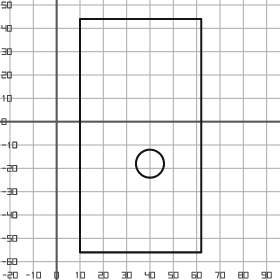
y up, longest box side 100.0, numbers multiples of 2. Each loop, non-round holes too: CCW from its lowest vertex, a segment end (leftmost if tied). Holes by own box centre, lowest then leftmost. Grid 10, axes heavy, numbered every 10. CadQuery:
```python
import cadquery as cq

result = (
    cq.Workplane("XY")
    .moveTo(10.0, -56.0)
    .lineTo(62.0, -56.0)
    .lineTo(62.0, 44.0)
    .lineTo(10.0, 44.0)
    .close()
    .moveTo(40.0, -18.0)
    .circle(6.0)
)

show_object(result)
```